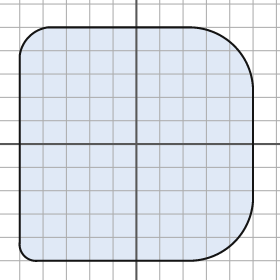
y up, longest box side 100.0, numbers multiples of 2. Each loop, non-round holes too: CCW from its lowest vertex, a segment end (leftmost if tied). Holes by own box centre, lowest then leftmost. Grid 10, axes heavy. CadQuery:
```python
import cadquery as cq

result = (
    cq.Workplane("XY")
    .moveTo(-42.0, -50.0)
    .lineTo(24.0, -50.0)
    .threePointArc((42.0, -42.0), (50.0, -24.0))
    .lineTo(50.0, 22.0)
    .threePointArc((42.0, 42.0), (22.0, 50.0))
    .lineTo(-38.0, 50.0)
    .threePointArc((-46.0, 46.0), (-50.0, 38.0))
    .lineTo(-50.0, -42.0)
    .threePointArc((-48.0, -48.0), (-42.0, -50.0))
    .close()
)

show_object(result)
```